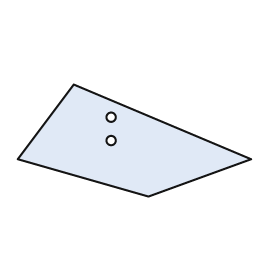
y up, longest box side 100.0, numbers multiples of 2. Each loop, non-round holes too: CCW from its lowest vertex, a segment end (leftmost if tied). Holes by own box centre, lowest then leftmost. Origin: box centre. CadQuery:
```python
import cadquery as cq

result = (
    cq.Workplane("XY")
    .moveTo(6.0, -24.0)
    .lineTo(50.0, -8.0)
    .lineTo(-26.0, 24.0)
    .lineTo(-50.0, -8.0)
    .close()
    .moveTo(-10.0, 0.0)
    .circle(2.0)
    .moveTo(-10.0, 10.0)
    .circle(2.0)
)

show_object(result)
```